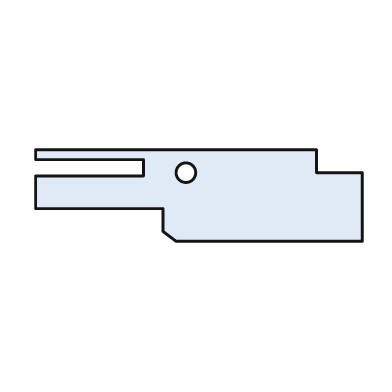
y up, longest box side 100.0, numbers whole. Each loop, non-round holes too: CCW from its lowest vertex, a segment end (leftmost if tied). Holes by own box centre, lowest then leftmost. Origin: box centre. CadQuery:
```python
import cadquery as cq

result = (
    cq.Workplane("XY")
    .moveTo(-7.0, -14.0)
    .lineTo(50.0, -14.0)
    .lineTo(50.0, 7.0)
    .lineTo(36.0, 7.0)
    .lineTo(36.0, 14.0)
    .lineTo(-50.0, 14.0)
    .lineTo(-50.0, 11.0)
    .lineTo(-17.0, 11.0)
    .lineTo(-17.0, 6.0)
    .lineTo(-50.0, 6.0)
    .lineTo(-50.0, -4.0)
    .lineTo(-11.0, -4.0)
    .lineTo(-11.0, -11.0)
    .close()
    .moveTo(-4.0, 7.0)
    .circle(3.0)
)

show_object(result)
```